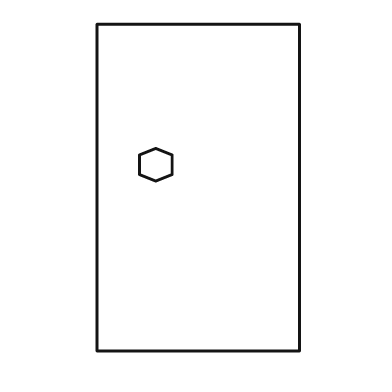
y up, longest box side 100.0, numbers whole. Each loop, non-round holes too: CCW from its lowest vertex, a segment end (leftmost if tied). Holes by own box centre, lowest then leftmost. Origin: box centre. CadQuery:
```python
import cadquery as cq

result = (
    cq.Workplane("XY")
    .moveTo(-31.0, -50.0)
    .lineTo(31.0, -50.0)
    .lineTo(31.0, 50.0)
    .lineTo(-31.0, 50.0)
    .close()
    .moveTo(-13.0, 2.0)
    .lineTo(-8.0, 4.0)
    .lineTo(-8.0, 10.0)
    .lineTo(-13.0, 12.0)
    .lineTo(-18.0, 10.0)
    .lineTo(-18.0, 4.0)
    .close()
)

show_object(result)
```